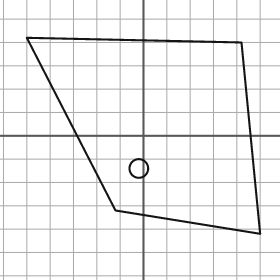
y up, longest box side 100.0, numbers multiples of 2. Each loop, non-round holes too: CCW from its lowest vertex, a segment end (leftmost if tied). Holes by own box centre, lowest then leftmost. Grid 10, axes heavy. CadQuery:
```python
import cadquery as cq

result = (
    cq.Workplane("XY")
    .moveTo(50.0, -42.0)
    .lineTo(42.0, 40.0)
    .lineTo(-50.0, 42.0)
    .lineTo(-12.0, -32.0)
    .close()
    .moveTo(-2.0, -14.0)
    .circle(4.0)
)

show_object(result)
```